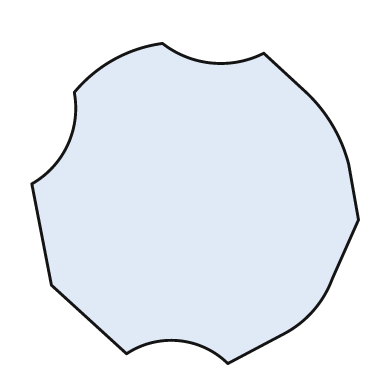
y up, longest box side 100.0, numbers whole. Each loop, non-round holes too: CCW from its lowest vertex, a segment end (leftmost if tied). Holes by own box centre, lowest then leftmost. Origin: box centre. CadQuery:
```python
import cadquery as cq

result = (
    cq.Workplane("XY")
    .moveTo(10.0, -49.0)
    .lineTo(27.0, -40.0)
    .threePointArc((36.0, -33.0), (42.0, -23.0))
    .lineTo(50.0, -5.0)
    .lineTo(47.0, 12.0)
    .threePointArc((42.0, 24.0), (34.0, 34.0))
    .lineTo(21.0, 46.0)
    .threePointArc((5.0, 43.0), (-10.0, 49.0))
    .threePointArc((-25.0, 44.0), (-37.0, 34.0))
    .threePointArc((-39.0, 18.0), (-50.0, 6.0))
    .lineTo(-44.0, -25.0)
    .lineTo(-21.0, -46.0)
    .threePointArc((-5.0, -42.0), (10.0, -49.0))
    .close()
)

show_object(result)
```